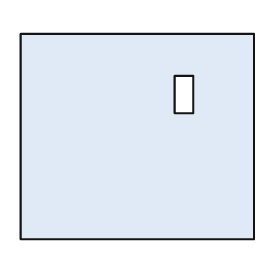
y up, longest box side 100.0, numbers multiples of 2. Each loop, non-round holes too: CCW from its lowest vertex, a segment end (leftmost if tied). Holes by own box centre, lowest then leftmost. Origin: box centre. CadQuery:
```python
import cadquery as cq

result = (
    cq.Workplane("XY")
    .moveTo(-50.0, -44.0)
    .lineTo(50.0, -44.0)
    .lineTo(50.0, 44.0)
    .lineTo(-50.0, 44.0)
    .close()
    .moveTo(16.0, 10.0)
    .lineTo(24.0, 10.0)
    .lineTo(24.0, 26.0)
    .lineTo(16.0, 26.0)
    .close()
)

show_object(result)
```